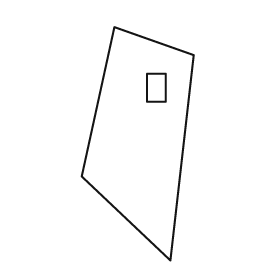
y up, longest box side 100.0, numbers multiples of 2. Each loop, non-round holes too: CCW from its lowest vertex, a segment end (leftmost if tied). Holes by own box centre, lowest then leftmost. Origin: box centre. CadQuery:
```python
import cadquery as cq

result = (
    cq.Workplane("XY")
    .moveTo(14.0, -50.0)
    .lineTo(24.0, 38.0)
    .lineTo(-10.0, 50.0)
    .lineTo(-24.0, -14.0)
    .close()
    .moveTo(4.0, 18.0)
    .lineTo(12.0, 18.0)
    .lineTo(12.0, 30.0)
    .lineTo(4.0, 30.0)
    .close()
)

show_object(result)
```